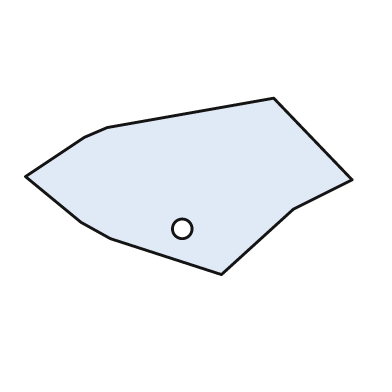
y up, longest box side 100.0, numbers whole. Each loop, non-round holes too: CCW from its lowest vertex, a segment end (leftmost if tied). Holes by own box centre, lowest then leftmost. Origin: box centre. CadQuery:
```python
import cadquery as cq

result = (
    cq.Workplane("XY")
    .moveTo(10.0, -27.0)
    .lineTo(32.0, -7.0)
    .lineTo(50.0, 2.0)
    .lineTo(26.0, 27.0)
    .lineTo(-25.0, 18.0)
    .lineTo(-32.0, 15.0)
    .lineTo(-50.0, 3.0)
    .lineTo(-33.0, -11.0)
    .lineTo(-24.0, -16.0)
    .close()
    .moveTo(-2.0, -13.0)
    .circle(3.0)
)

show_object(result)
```